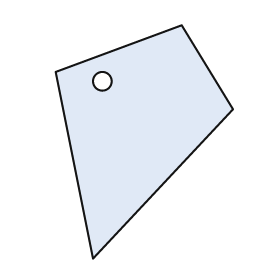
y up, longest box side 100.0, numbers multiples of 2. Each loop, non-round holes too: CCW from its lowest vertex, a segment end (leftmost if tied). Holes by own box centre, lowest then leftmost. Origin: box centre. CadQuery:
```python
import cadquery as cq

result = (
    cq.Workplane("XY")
    .moveTo(-22.0, -50.0)
    .lineTo(38.0, 14.0)
    .lineTo(16.0, 50.0)
    .lineTo(-38.0, 30.0)
    .close()
    .moveTo(-18.0, 26.0)
    .circle(4.0)
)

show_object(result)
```